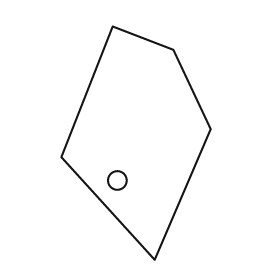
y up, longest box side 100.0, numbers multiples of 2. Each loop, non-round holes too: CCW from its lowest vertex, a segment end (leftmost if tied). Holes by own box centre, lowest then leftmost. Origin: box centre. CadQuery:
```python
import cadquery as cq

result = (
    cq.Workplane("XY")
    .moveTo(8.0, -50.0)
    .lineTo(32.0, 6.0)
    .lineTo(16.0, 40.0)
    .lineTo(-10.0, 50.0)
    .lineTo(-32.0, -6.0)
    .close()
    .moveTo(-8.0, -16.0)
    .circle(4.0)
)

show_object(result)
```